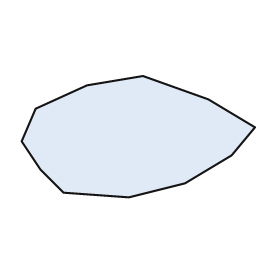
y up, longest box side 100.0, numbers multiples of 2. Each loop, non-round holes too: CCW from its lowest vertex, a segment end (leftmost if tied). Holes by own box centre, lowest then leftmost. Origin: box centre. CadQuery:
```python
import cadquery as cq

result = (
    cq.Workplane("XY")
    .moveTo(-4.0, -26.0)
    .lineTo(20.0, -20.0)
    .lineTo(40.0, -8.0)
    .lineTo(50.0, 4.0)
    .lineTo(30.0, 16.0)
    .lineTo(2.0, 26.0)
    .lineTo(-22.0, 22.0)
    .lineTo(-44.0, 12.0)
    .lineTo(-50.0, -2.0)
    .lineTo(-42.0, -14.0)
    .lineTo(-32.0, -24.0)
    .close()
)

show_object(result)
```